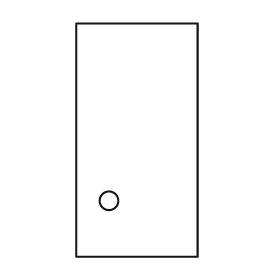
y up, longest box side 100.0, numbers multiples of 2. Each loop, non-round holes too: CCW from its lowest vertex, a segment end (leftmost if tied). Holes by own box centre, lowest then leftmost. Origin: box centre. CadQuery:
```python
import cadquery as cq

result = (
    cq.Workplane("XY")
    .moveTo(-26.0, -50.0)
    .lineTo(26.0, -50.0)
    .lineTo(26.0, 50.0)
    .lineTo(-26.0, 50.0)
    .close()
    .moveTo(-12.0, -26.0)
    .circle(4.0)
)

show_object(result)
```